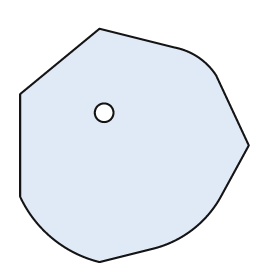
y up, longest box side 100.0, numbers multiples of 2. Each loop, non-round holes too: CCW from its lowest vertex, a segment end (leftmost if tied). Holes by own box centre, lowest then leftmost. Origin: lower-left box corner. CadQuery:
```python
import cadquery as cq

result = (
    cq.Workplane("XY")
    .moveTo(34.0, 0.0)
    .lineTo(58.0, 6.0)
    .threePointArc((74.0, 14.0), (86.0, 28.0))
    .lineTo(98.0, 50.0)
    .lineTo(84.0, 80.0)
    .threePointArc((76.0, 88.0), (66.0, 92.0))
    .lineTo(34.0, 100.0)
    .lineTo(0.0, 72.0)
    .lineTo(0.0, 28.0)
    .threePointArc((14.0, 10.0), (34.0, 0.0))
    .close()
    .moveTo(36.0, 64.0)
    .circle(4.0)
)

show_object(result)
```